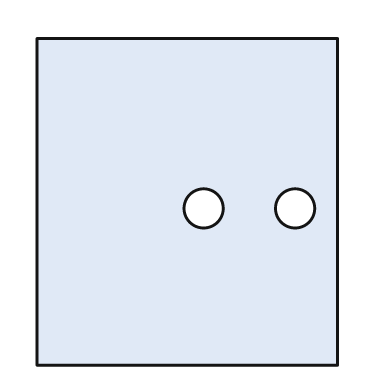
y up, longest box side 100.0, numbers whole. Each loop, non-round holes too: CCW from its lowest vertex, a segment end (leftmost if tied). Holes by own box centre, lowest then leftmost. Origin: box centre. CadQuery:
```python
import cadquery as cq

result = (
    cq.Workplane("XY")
    .moveTo(-46.0, -50.0)
    .lineTo(46.0, -50.0)
    .lineTo(46.0, 50.0)
    .lineTo(-46.0, 50.0)
    .close()
    .moveTo(5.0, -2.0)
    .circle(6.0)
    .moveTo(33.0, -2.0)
    .circle(6.0)
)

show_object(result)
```